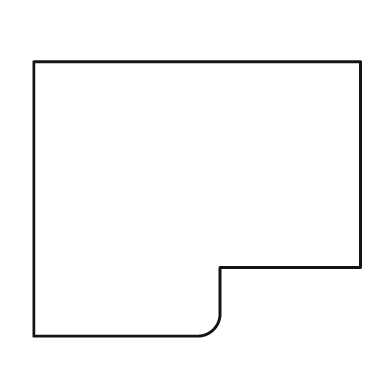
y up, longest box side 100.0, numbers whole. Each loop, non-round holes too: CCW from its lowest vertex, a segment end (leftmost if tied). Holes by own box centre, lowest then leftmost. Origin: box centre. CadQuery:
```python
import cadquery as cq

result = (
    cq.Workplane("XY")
    .moveTo(-50.0, -42.0)
    .lineTo(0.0, -42.0)
    .threePointArc((5.0, -40.0), (7.0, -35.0))
    .lineTo(7.0, -21.0)
    .lineTo(50.0, -21.0)
    .lineTo(50.0, 42.0)
    .lineTo(-50.0, 42.0)
    .close()
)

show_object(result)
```